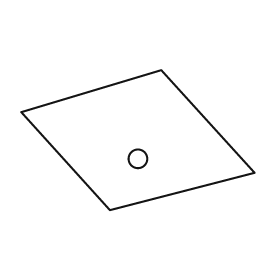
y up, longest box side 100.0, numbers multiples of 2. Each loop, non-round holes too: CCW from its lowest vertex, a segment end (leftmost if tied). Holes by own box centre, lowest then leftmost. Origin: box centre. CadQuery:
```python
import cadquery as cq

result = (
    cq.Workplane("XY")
    .moveTo(-12.0, -30.0)
    .lineTo(50.0, -14.0)
    .lineTo(10.0, 30.0)
    .lineTo(-50.0, 12.0)
    .close()
    .moveTo(0.0, -8.0)
    .circle(4.0)
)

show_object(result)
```